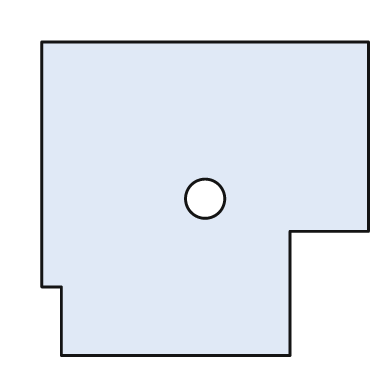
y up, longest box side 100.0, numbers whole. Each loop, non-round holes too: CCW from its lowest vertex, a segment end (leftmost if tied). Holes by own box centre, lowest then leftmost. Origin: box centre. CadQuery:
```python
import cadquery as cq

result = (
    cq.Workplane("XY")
    .moveTo(-44.0, -48.0)
    .lineTo(26.0, -48.0)
    .lineTo(26.0, -10.0)
    .lineTo(50.0, -10.0)
    .lineTo(50.0, 48.0)
    .lineTo(-50.0, 48.0)
    .lineTo(-50.0, -27.0)
    .lineTo(-44.0, -27.0)
    .close()
    .moveTo(0.0, 0.0)
    .circle(6.0)
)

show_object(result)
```